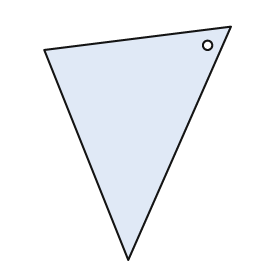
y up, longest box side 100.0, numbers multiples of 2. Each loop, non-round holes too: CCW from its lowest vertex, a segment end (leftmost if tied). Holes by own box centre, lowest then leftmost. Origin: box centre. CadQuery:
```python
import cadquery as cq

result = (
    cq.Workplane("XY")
    .moveTo(-4.0, -50.0)
    .lineTo(40.0, 50.0)
    .lineTo(-40.0, 40.0)
    .close()
    .moveTo(30.0, 42.0)
    .circle(2.0)
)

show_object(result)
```